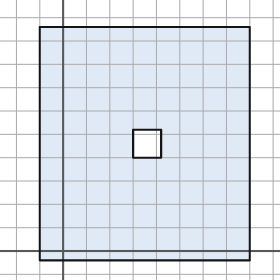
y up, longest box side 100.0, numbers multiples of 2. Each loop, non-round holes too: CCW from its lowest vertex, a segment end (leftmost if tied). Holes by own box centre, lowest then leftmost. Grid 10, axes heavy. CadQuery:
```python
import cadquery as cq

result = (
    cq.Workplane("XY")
    .moveTo(-10.0, -4.0)
    .lineTo(80.0, -4.0)
    .lineTo(80.0, 96.0)
    .lineTo(-10.0, 96.0)
    .close()
    .moveTo(30.0, 40.0)
    .lineTo(42.0, 40.0)
    .lineTo(42.0, 52.0)
    .lineTo(30.0, 52.0)
    .close()
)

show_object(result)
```